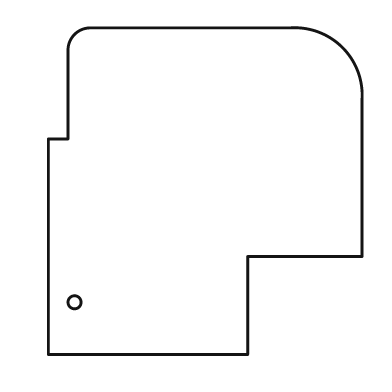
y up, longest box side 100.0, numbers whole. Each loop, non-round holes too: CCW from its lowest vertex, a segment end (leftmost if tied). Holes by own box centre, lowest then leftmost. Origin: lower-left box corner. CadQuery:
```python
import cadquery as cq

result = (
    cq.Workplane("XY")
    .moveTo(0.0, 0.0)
    .lineTo(61.0, 0.0)
    .lineTo(61.0, 30.0)
    .lineTo(96.0, 30.0)
    .lineTo(96.0, 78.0)
    .threePointArc((90.0, 94.0), (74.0, 100.0))
    .lineTo(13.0, 100.0)
    .threePointArc((8.0, 98.0), (6.0, 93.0))
    .lineTo(6.0, 66.0)
    .lineTo(0.0, 66.0)
    .close()
    .moveTo(8.0, 16.0)
    .circle(2.0)
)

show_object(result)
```